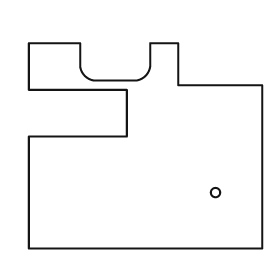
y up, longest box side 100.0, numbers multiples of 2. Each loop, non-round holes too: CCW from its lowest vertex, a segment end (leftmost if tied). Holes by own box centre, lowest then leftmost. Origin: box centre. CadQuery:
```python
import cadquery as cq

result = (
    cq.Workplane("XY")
    .moveTo(-50.0, -44.0)
    .lineTo(50.0, -44.0)
    .lineTo(50.0, 26.0)
    .lineTo(14.0, 26.0)
    .lineTo(14.0, 44.0)
    .lineTo(2.0, 44.0)
    .lineTo(2.0, 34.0)
    .threePointArc((0.0, 30.0), (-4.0, 28.0))
    .lineTo(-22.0, 28.0)
    .threePointArc((-26.0, 30.0), (-28.0, 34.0))
    .lineTo(-28.0, 44.0)
    .lineTo(-50.0, 44.0)
    .lineTo(-50.0, 24.0)
    .lineTo(-8.0, 24.0)
    .lineTo(-8.0, 4.0)
    .lineTo(-50.0, 4.0)
    .close()
    .moveTo(30.0, -20.0)
    .circle(2.0)
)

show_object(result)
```